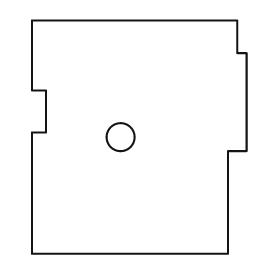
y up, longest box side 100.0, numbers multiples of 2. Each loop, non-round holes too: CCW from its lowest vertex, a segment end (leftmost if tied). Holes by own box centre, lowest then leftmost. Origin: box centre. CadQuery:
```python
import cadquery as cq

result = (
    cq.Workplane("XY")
    .moveTo(-46.0, -50.0)
    .lineTo(38.0, -50.0)
    .lineTo(38.0, -6.0)
    .lineTo(46.0, -6.0)
    .lineTo(46.0, 36.0)
    .lineTo(42.0, 36.0)
    .lineTo(42.0, 50.0)
    .lineTo(-46.0, 50.0)
    .lineTo(-46.0, 20.0)
    .lineTo(-40.0, 20.0)
    .lineTo(-40.0, 2.0)
    .lineTo(-46.0, 2.0)
    .close()
    .moveTo(-8.0, 0.0)
    .circle(6.0)
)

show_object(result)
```